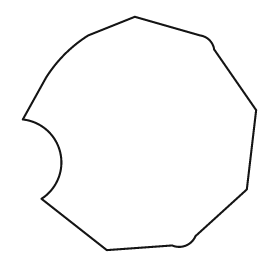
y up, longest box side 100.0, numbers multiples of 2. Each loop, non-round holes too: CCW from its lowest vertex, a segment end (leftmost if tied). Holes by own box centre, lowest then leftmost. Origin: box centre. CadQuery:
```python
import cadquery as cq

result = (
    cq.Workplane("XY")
    .moveTo(-14.0, -50.0)
    .lineTo(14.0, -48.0)
    .threePointArc((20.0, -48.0), (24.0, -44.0))
    .lineTo(46.0, -24.0)
    .lineTo(50.0, 10.0)
    .lineTo(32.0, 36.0)
    .threePointArc((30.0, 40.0), (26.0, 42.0))
    .lineTo(-2.0, 50.0)
    .lineTo(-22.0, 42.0)
    .threePointArc((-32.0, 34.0), (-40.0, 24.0))
    .lineTo(-50.0, 6.0)
    .threePointArc((-34.0, -8.0), (-42.0, -28.0))
    .close()
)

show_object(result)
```